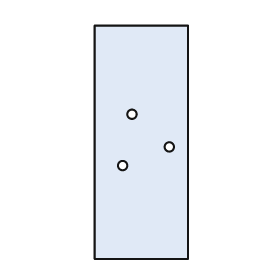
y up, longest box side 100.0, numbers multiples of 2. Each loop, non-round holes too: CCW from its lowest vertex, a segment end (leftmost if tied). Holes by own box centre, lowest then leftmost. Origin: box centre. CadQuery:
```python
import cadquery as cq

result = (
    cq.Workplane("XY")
    .moveTo(-20.0, -50.0)
    .lineTo(20.0, -50.0)
    .lineTo(20.0, 50.0)
    .lineTo(-20.0, 50.0)
    .close()
    .moveTo(-8.0, -10.0)
    .circle(2.0)
    .moveTo(12.0, -2.0)
    .circle(2.0)
    .moveTo(-4.0, 12.0)
    .circle(2.0)
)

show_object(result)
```